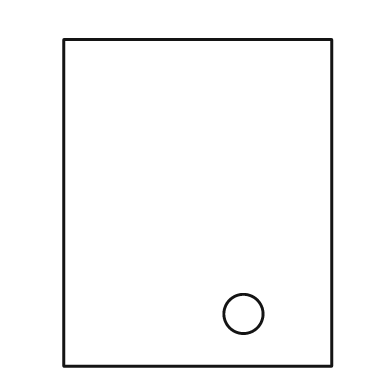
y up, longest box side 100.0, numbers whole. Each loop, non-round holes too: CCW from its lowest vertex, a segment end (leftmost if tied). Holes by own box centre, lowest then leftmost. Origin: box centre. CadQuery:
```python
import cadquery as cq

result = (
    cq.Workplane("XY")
    .moveTo(-41.0, -50.0)
    .lineTo(41.0, -50.0)
    .lineTo(41.0, 50.0)
    .lineTo(-41.0, 50.0)
    .close()
    .moveTo(14.0, -34.0)
    .circle(6.0)
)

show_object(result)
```